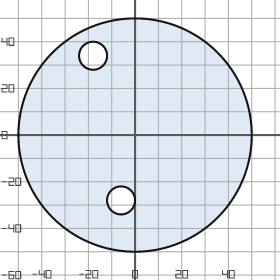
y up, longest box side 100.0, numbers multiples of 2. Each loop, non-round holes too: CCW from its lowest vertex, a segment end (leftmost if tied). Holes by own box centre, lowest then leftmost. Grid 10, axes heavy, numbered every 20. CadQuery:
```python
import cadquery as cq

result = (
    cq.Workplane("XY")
    .moveTo(0.0, 0.0)
    .circle(50.0)
    .moveTo(-6.0, -28.0)
    .circle(6.0)
    .moveTo(-18.0, 34.0)
    .circle(6.0)
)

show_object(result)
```